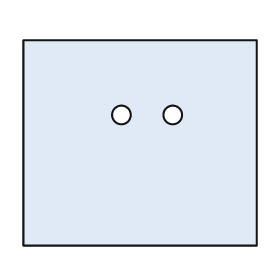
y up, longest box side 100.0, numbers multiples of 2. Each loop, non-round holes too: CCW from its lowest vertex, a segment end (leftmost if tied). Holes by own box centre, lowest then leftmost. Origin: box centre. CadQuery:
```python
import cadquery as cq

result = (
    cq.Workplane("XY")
    .moveTo(-50.0, -44.0)
    .lineTo(50.0, -44.0)
    .lineTo(50.0, 44.0)
    .lineTo(-50.0, 44.0)
    .close()
    .moveTo(-8.0, 12.0)
    .circle(4.0)
    .moveTo(14.0, 12.0)
    .circle(4.0)
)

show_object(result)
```